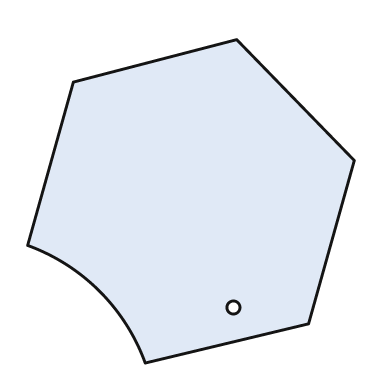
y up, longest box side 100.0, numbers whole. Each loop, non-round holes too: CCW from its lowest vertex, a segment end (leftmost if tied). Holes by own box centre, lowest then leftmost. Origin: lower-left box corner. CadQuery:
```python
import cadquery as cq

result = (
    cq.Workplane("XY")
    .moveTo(36.0, 0.0)
    .lineTo(86.0, 12.0)
    .lineTo(100.0, 62.0)
    .lineTo(64.0, 99.0)
    .lineTo(14.0, 86.0)
    .lineTo(0.0, 36.0)
    .threePointArc((22.0, 22.0), (36.0, 0.0))
    .close()
    .moveTo(63.0, 17.0)
    .circle(2.0)
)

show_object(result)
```